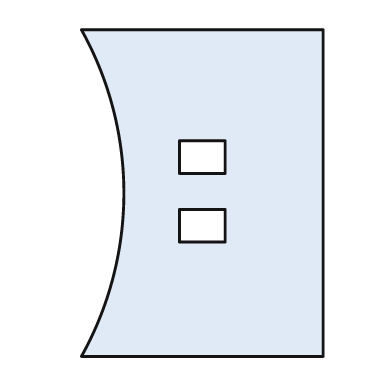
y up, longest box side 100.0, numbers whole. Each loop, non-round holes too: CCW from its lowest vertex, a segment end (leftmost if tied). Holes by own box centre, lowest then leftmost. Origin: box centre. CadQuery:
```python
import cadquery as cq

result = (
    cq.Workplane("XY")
    .moveTo(-37.0, -50.0)
    .lineTo(37.0, -50.0)
    .lineTo(37.0, 50.0)
    .lineTo(-37.0, 50.0)
    .threePointArc((-24.0, 0.0), (-37.0, -50.0))
    .close()
    .moveTo(-7.0, -15.0)
    .lineTo(7.0, -15.0)
    .lineTo(7.0, -5.0)
    .lineTo(-7.0, -5.0)
    .close()
    .moveTo(-7.0, 6.0)
    .lineTo(7.0, 6.0)
    .lineTo(7.0, 16.0)
    .lineTo(-7.0, 16.0)
    .close()
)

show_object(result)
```